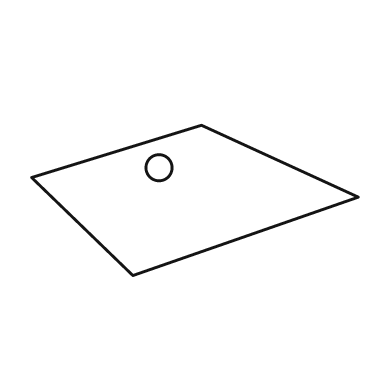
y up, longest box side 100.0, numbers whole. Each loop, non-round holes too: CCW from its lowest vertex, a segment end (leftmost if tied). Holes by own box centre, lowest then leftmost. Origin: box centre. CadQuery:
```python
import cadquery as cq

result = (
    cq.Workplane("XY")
    .moveTo(-19.0, -23.0)
    .lineTo(50.0, 1.0)
    .lineTo(2.0, 23.0)
    .lineTo(-50.0, 7.0)
    .close()
    .moveTo(-11.0, 10.0)
    .circle(4.0)
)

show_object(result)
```